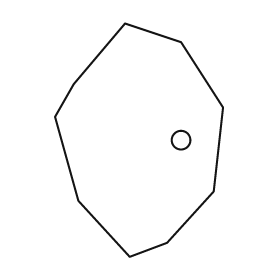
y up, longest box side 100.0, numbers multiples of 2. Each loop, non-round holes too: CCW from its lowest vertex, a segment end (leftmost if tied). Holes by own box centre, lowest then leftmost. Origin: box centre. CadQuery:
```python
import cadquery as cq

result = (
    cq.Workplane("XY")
    .moveTo(-4.0, -50.0)
    .lineTo(12.0, -44.0)
    .lineTo(32.0, -22.0)
    .lineTo(36.0, 14.0)
    .lineTo(18.0, 42.0)
    .lineTo(-6.0, 50.0)
    .lineTo(-28.0, 24.0)
    .lineTo(-36.0, 10.0)
    .lineTo(-26.0, -26.0)
    .close()
    .moveTo(18.0, 0.0)
    .circle(4.0)
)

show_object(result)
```